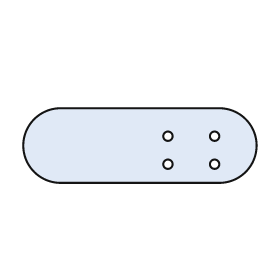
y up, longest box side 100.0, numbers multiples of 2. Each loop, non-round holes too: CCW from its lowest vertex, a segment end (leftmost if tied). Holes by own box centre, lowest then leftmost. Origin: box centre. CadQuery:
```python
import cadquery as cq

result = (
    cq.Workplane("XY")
    .moveTo(-34.0, -16.0)
    .lineTo(34.0, -16.0)
    .threePointArc((50.0, 0.0), (34.0, 16.0))
    .lineTo(-34.0, 16.0)
    .threePointArc((-50.0, 0.0), (-34.0, -16.0))
    .close()
    .moveTo(12.0, -8.0)
    .circle(2.0)
    .moveTo(32.0, -8.0)
    .circle(2.0)
    .moveTo(12.0, 4.0)
    .circle(2.0)
    .moveTo(32.0, 4.0)
    .circle(2.0)
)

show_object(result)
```